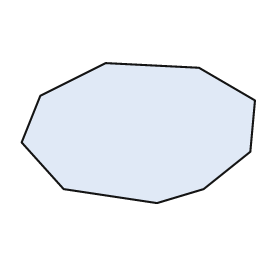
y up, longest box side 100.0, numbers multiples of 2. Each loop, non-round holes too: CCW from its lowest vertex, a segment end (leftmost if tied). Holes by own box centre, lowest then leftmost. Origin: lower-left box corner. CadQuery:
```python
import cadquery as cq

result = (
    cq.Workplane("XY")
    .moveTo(58.0, 0.0)
    .lineTo(78.0, 6.0)
    .lineTo(98.0, 22.0)
    .lineTo(100.0, 44.0)
    .lineTo(76.0, 58.0)
    .lineTo(36.0, 60.0)
    .lineTo(8.0, 46.0)
    .lineTo(0.0, 26.0)
    .lineTo(18.0, 6.0)
    .close()
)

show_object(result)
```